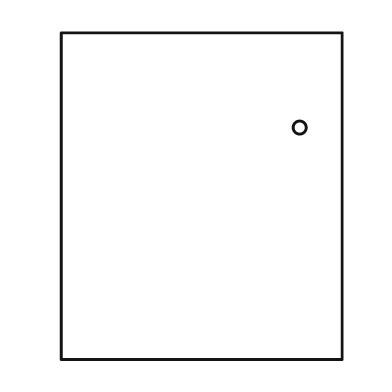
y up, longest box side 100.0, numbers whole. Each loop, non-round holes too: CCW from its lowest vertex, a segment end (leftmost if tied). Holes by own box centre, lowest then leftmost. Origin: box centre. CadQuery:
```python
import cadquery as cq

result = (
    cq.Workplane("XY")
    .moveTo(-43.0, -50.0)
    .lineTo(43.0, -50.0)
    .lineTo(43.0, 50.0)
    .lineTo(-43.0, 50.0)
    .close()
    .moveTo(30.0, 21.0)
    .circle(2.0)
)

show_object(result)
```